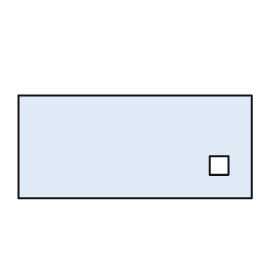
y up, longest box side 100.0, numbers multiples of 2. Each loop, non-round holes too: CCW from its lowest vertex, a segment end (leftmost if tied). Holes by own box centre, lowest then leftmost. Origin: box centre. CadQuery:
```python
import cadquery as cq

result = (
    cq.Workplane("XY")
    .moveTo(-50.0, -22.0)
    .lineTo(50.0, -22.0)
    .lineTo(50.0, 22.0)
    .lineTo(-50.0, 22.0)
    .close()
    .moveTo(32.0, -12.0)
    .lineTo(40.0, -12.0)
    .lineTo(40.0, -4.0)
    .lineTo(32.0, -4.0)
    .close()
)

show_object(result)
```